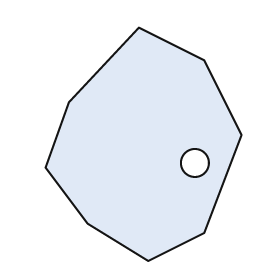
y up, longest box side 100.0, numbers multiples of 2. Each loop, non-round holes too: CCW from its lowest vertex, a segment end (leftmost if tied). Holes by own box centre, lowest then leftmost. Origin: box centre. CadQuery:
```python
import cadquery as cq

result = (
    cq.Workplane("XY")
    .moveTo(2.0, -50.0)
    .lineTo(26.0, -38.0)
    .lineTo(42.0, 4.0)
    .lineTo(26.0, 36.0)
    .lineTo(-2.0, 50.0)
    .lineTo(-32.0, 18.0)
    .lineTo(-42.0, -10.0)
    .lineTo(-24.0, -34.0)
    .close()
    .moveTo(22.0, -8.0)
    .circle(6.0)
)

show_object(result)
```